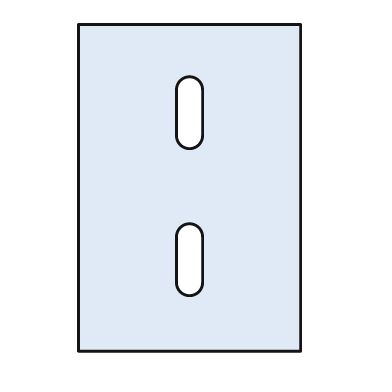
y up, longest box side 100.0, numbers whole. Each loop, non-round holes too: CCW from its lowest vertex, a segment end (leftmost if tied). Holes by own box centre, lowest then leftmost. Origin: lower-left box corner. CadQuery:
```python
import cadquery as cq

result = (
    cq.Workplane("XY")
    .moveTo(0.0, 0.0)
    .lineTo(68.0, 0.0)
    .lineTo(68.0, 100.0)
    .lineTo(0.0, 100.0)
    .close()
    .moveTo(30.0, 21.0)
    .threePointArc((34.0, 17.0), (38.0, 21.0))
    .lineTo(38.0, 35.0)
    .threePointArc((34.0, 39.0), (30.0, 35.0))
    .close()
    .moveTo(30.0, 66.0)
    .threePointArc((34.0, 62.0), (38.0, 66.0))
    .lineTo(38.0, 80.0)
    .threePointArc((34.0, 84.0), (30.0, 80.0))
    .close()
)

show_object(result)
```